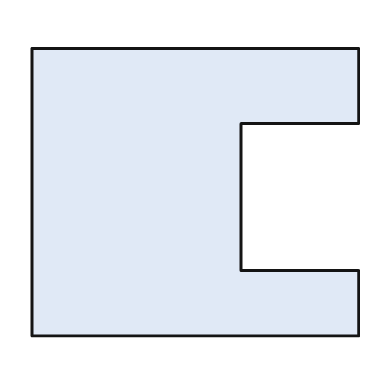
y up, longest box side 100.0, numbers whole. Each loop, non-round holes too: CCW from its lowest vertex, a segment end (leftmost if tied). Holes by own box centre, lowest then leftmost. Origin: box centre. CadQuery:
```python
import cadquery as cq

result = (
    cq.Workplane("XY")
    .moveTo(-50.0, -44.0)
    .lineTo(50.0, -44.0)
    .lineTo(50.0, -24.0)
    .lineTo(14.0, -24.0)
    .lineTo(14.0, 21.0)
    .lineTo(50.0, 21.0)
    .lineTo(50.0, 44.0)
    .lineTo(-50.0, 44.0)
    .close()
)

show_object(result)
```